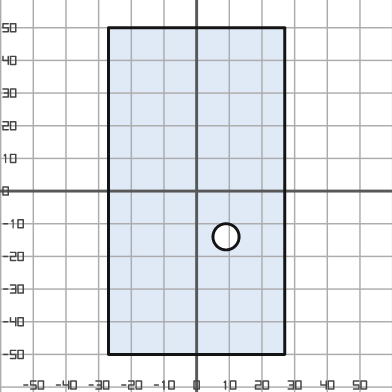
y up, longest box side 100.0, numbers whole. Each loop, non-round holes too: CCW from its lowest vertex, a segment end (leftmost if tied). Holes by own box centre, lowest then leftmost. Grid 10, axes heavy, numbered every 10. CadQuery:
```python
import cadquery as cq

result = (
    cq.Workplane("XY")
    .moveTo(-27.0, -50.0)
    .lineTo(27.0, -50.0)
    .lineTo(27.0, 50.0)
    .lineTo(-27.0, 50.0)
    .close()
    .moveTo(9.0, -14.0)
    .circle(4.0)
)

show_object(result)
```